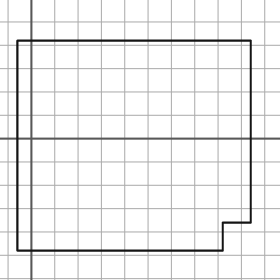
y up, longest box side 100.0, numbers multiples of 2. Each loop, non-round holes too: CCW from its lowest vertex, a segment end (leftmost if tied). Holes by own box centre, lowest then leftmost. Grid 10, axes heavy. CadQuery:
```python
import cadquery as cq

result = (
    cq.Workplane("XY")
    .moveTo(-6.0, -48.0)
    .lineTo(82.0, -48.0)
    .lineTo(82.0, -36.0)
    .lineTo(94.0, -36.0)
    .lineTo(94.0, 42.0)
    .lineTo(-6.0, 42.0)
    .close()
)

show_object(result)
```